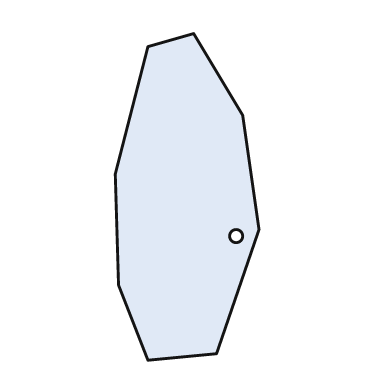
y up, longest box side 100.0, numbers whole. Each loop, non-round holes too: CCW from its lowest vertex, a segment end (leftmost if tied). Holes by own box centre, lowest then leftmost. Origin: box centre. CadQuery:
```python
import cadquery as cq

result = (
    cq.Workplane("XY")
    .moveTo(-12.0, -50.0)
    .lineTo(9.0, -48.0)
    .lineTo(22.0, -10.0)
    .lineTo(17.0, 25.0)
    .lineTo(2.0, 50.0)
    .lineTo(-12.0, 46.0)
    .lineTo(-22.0, 7.0)
    .lineTo(-21.0, -27.0)
    .close()
    .moveTo(15.0, -12.0)
    .circle(2.0)
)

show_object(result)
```